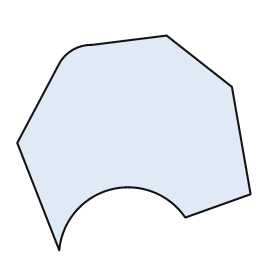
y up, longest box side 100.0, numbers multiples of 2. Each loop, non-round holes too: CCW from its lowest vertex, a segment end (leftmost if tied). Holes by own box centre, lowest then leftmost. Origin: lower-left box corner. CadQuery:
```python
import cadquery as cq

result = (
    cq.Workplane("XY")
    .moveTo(18.0, 0.0)
    .threePointArc((40.0, 26.0), (72.0, 14.0))
    .lineTo(100.0, 24.0)
    .lineTo(92.0, 70.0)
    .lineTo(64.0, 92.0)
    .lineTo(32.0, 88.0)
    .threePointArc((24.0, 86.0), (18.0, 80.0))
    .lineTo(0.0, 46.0)
    .close()
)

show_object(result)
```